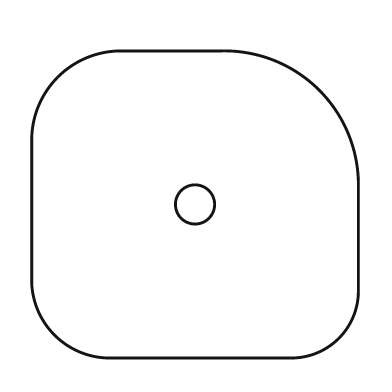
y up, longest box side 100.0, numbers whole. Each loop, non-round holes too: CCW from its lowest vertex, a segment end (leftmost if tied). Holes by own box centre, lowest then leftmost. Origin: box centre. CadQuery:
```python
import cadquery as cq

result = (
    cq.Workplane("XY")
    .moveTo(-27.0, -47.0)
    .lineTo(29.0, -47.0)
    .threePointArc((44.0, -41.0), (50.0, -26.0))
    .lineTo(50.0, 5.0)
    .threePointArc((38.0, 35.0), (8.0, 47.0))
    .lineTo(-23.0, 47.0)
    .threePointArc((-42.0, 39.0), (-50.0, 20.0))
    .lineTo(-50.0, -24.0)
    .threePointArc((-43.0, -40.0), (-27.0, -47.0))
    .close()
    .moveTo(0.0, 0.0)
    .circle(6.0)
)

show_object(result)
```